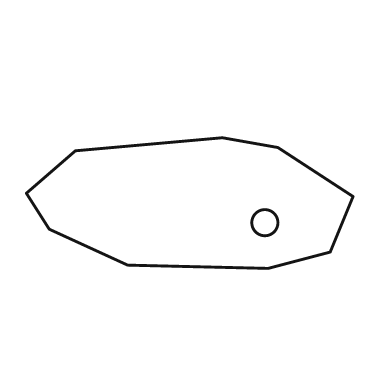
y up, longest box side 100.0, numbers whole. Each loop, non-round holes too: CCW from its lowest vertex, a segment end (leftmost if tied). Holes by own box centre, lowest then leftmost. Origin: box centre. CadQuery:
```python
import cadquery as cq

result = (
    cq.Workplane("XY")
    .moveTo(24.0, -20.0)
    .lineTo(43.0, -15.0)
    .lineTo(50.0, 2.0)
    .lineTo(27.0, 17.0)
    .lineTo(10.0, 20.0)
    .lineTo(-35.0, 16.0)
    .lineTo(-50.0, 3.0)
    .lineTo(-43.0, -8.0)
    .lineTo(-19.0, -19.0)
    .close()
    .moveTo(23.0, -6.0)
    .circle(4.0)
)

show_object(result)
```